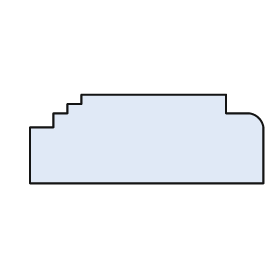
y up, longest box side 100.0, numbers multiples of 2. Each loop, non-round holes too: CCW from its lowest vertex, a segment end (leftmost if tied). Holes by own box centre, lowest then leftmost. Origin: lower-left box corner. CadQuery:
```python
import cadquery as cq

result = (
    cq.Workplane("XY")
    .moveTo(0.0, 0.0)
    .lineTo(100.0, 0.0)
    .lineTo(100.0, 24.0)
    .threePointArc((98.0, 28.0), (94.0, 30.0))
    .lineTo(84.0, 30.0)
    .lineTo(84.0, 38.0)
    .lineTo(22.0, 38.0)
    .lineTo(22.0, 34.0)
    .lineTo(16.0, 34.0)
    .lineTo(16.0, 30.0)
    .lineTo(10.0, 30.0)
    .lineTo(10.0, 24.0)
    .lineTo(0.0, 24.0)
    .close()
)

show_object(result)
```